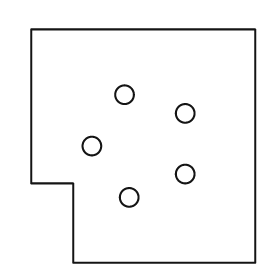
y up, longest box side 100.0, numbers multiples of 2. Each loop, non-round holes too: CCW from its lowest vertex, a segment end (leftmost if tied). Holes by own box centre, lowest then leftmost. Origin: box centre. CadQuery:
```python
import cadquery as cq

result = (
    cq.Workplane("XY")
    .moveTo(-30.0, -50.0)
    .lineTo(48.0, -50.0)
    .lineTo(48.0, 50.0)
    .lineTo(-48.0, 50.0)
    .lineTo(-48.0, -16.0)
    .lineTo(-30.0, -16.0)
    .close()
    .moveTo(-6.0, -22.0)
    .circle(4.0)
    .moveTo(18.0, -12.0)
    .circle(4.0)
    .moveTo(-22.0, 0.0)
    .circle(4.0)
    .moveTo(18.0, 14.0)
    .circle(4.0)
    .moveTo(-8.0, 22.0)
    .circle(4.0)
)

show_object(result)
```